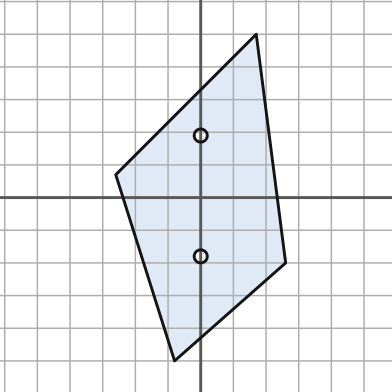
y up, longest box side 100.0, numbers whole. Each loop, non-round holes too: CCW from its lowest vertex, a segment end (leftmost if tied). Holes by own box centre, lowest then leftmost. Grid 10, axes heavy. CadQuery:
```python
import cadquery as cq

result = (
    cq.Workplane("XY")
    .moveTo(-8.0, -50.0)
    .lineTo(26.0, -20.0)
    .lineTo(17.0, 50.0)
    .lineTo(-26.0, 7.0)
    .close()
    .moveTo(0.0, -18.0)
    .circle(2.0)
    .moveTo(0.0, 19.0)
    .circle(2.0)
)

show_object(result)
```